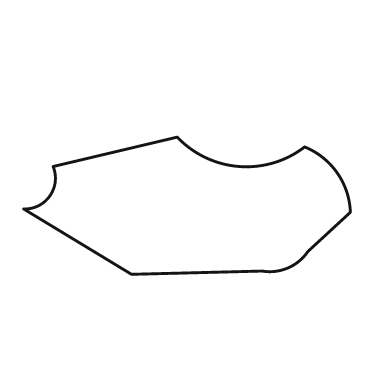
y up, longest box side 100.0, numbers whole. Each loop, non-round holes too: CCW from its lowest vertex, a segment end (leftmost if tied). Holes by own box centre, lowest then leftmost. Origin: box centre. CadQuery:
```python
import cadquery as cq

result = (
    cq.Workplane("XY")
    .moveTo(-17.0, -21.0)
    .lineTo(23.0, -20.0)
    .threePointArc((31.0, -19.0), (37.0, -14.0))
    .lineTo(50.0, -2.0)
    .threePointArc((46.0, 10.0), (36.0, 18.0))
    .threePointArc((16.0, 12.0), (-3.0, 21.0))
    .lineTo(-41.0, 12.0)
    .threePointArc((-42.0, 3.0), (-50.0, -1.0))
    .close()
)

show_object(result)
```